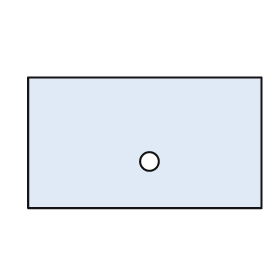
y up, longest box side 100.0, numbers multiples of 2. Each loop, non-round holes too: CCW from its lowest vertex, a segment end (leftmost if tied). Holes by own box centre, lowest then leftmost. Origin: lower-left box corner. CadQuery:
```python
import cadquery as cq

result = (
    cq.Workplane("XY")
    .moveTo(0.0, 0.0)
    .lineTo(100.0, 0.0)
    .lineTo(100.0, 56.0)
    .lineTo(0.0, 56.0)
    .close()
    .moveTo(52.0, 20.0)
    .circle(4.0)
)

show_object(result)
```